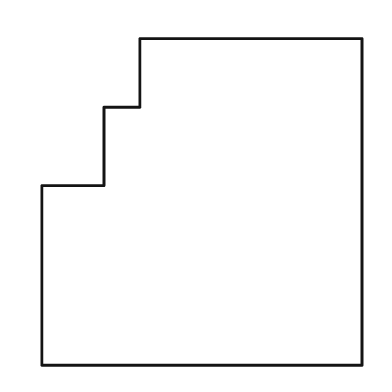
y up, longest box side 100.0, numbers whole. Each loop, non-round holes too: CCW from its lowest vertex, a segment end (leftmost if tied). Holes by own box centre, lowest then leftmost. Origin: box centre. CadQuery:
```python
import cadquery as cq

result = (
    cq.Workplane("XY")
    .moveTo(-49.0, -50.0)
    .lineTo(49.0, -50.0)
    .lineTo(49.0, 50.0)
    .lineTo(-19.0, 50.0)
    .lineTo(-19.0, 29.0)
    .lineTo(-30.0, 29.0)
    .lineTo(-30.0, 5.0)
    .lineTo(-49.0, 5.0)
    .close()
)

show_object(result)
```